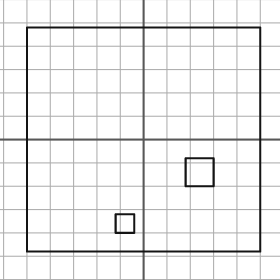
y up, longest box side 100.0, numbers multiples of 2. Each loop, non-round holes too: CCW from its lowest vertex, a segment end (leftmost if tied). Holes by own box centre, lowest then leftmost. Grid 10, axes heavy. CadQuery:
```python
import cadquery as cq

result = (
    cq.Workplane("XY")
    .moveTo(-50.0, -48.0)
    .lineTo(50.0, -48.0)
    .lineTo(50.0, 48.0)
    .lineTo(-50.0, 48.0)
    .close()
    .moveTo(-12.0, -40.0)
    .lineTo(-4.0, -40.0)
    .lineTo(-4.0, -32.0)
    .lineTo(-12.0, -32.0)
    .close()
    .moveTo(18.0, -20.0)
    .lineTo(30.0, -20.0)
    .lineTo(30.0, -8.0)
    .lineTo(18.0, -8.0)
    .close()
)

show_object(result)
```